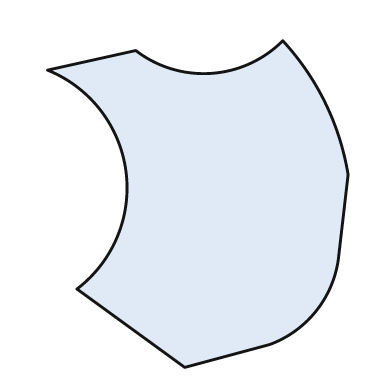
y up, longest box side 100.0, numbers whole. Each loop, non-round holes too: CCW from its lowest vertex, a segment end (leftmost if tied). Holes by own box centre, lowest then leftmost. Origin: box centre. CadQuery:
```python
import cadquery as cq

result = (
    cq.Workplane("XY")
    .moveTo(-4.0, -50.0)
    .lineTo(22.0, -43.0)
    .threePointArc((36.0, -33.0), (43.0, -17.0))
    .lineTo(46.0, 9.0)
    .threePointArc((39.0, 31.0), (26.0, 50.0))
    .threePointArc((4.0, 40.0), (-19.0, 47.0))
    .lineTo(-46.0, 41.0)
    .threePointArc((-22.0, 10.0), (-37.0, -26.0))
    .close()
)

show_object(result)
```